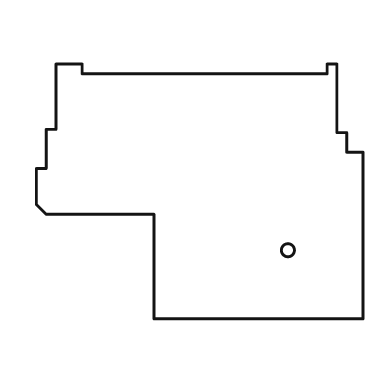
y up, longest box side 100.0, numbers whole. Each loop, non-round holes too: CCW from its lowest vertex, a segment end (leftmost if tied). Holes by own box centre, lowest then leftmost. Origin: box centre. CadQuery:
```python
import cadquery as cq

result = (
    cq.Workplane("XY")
    .moveTo(-14.0, -39.0)
    .lineTo(50.0, -39.0)
    .lineTo(50.0, 12.0)
    .lineTo(45.0, 12.0)
    .lineTo(45.0, 18.0)
    .lineTo(42.0, 18.0)
    .lineTo(42.0, 39.0)
    .lineTo(39.0, 39.0)
    .lineTo(39.0, 36.0)
    .lineTo(-36.0, 36.0)
    .lineTo(-36.0, 39.0)
    .lineTo(-44.0, 39.0)
    .lineTo(-44.0, 19.0)
    .lineTo(-47.0, 19.0)
    .lineTo(-47.0, 7.0)
    .lineTo(-50.0, 7.0)
    .lineTo(-50.0, -4.0)
    .lineTo(-47.0, -7.0)
    .lineTo(-14.0, -7.0)
    .close()
    .moveTo(27.0, -18.0)
    .circle(2.0)
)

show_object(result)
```